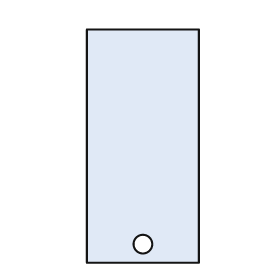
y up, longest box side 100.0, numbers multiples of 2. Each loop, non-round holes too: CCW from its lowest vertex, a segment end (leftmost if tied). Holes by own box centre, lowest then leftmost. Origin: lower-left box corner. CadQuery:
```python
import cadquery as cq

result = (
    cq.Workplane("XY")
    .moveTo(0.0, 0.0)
    .lineTo(48.0, 0.0)
    .lineTo(48.0, 100.0)
    .lineTo(0.0, 100.0)
    .close()
    .moveTo(24.0, 8.0)
    .circle(4.0)
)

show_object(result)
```